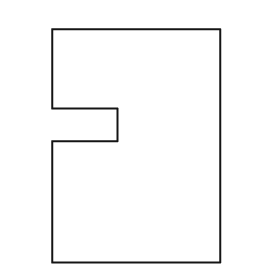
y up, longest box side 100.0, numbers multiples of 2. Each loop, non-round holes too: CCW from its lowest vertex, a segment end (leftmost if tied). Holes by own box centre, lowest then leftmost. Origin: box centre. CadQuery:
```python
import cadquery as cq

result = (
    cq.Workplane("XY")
    .moveTo(-36.0, -50.0)
    .lineTo(36.0, -50.0)
    .lineTo(36.0, 50.0)
    .lineTo(-36.0, 50.0)
    .lineTo(-36.0, 16.0)
    .lineTo(-8.0, 16.0)
    .lineTo(-8.0, 2.0)
    .lineTo(-36.0, 2.0)
    .close()
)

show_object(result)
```